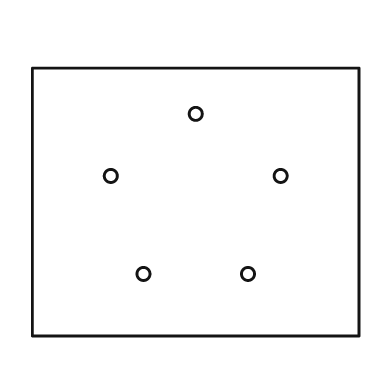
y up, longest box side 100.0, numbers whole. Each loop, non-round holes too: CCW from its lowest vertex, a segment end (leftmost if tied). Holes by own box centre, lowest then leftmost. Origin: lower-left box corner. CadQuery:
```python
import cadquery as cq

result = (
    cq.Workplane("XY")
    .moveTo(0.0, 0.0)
    .lineTo(100.0, 0.0)
    .lineTo(100.0, 82.0)
    .lineTo(0.0, 82.0)
    .close()
    .moveTo(34.0, 19.0)
    .circle(2.0)
    .moveTo(66.0, 19.0)
    .circle(2.0)
    .moveTo(24.0, 49.0)
    .circle(2.0)
    .moveTo(76.0, 49.0)
    .circle(2.0)
    .moveTo(50.0, 68.0)
    .circle(2.0)
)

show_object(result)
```